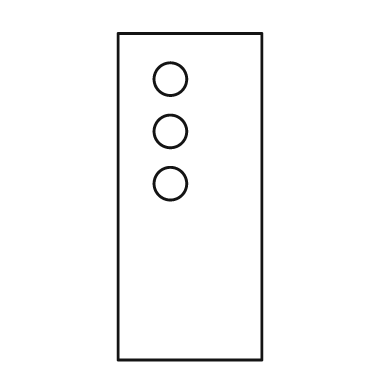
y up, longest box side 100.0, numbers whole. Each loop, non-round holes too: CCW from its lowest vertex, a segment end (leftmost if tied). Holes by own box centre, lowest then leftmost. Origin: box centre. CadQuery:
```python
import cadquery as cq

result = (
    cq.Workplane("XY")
    .moveTo(-22.0, -50.0)
    .lineTo(22.0, -50.0)
    .lineTo(22.0, 50.0)
    .lineTo(-22.0, 50.0)
    .close()
    .moveTo(-6.0, 4.0)
    .circle(5.0)
    .moveTo(-6.0, 20.0)
    .circle(5.0)
    .moveTo(-6.0, 36.0)
    .circle(5.0)
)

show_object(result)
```